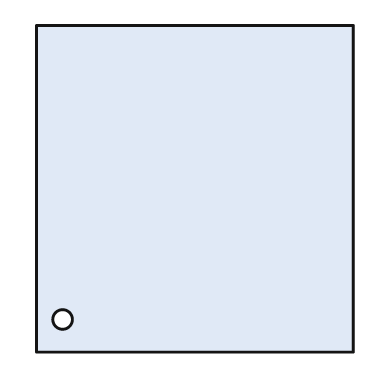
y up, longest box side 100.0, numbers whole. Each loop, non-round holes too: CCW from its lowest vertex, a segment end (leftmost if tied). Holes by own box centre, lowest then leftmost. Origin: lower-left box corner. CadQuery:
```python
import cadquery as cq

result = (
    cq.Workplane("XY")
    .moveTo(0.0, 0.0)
    .lineTo(97.0, 0.0)
    .lineTo(97.0, 100.0)
    .lineTo(0.0, 100.0)
    .close()
    .moveTo(8.0, 10.0)
    .circle(3.0)
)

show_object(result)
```